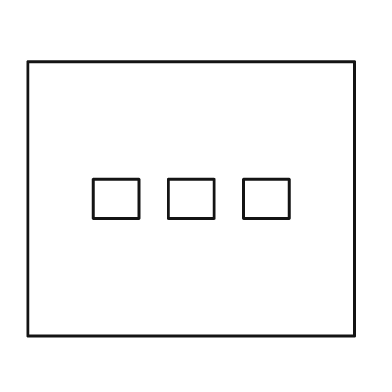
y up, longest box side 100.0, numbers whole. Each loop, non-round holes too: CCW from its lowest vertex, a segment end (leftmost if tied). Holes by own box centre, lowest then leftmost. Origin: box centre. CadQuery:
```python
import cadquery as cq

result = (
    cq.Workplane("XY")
    .moveTo(-50.0, -42.0)
    .lineTo(50.0, -42.0)
    .lineTo(50.0, 42.0)
    .lineTo(-50.0, 42.0)
    .close()
    .moveTo(-30.0, -6.0)
    .lineTo(-16.0, -6.0)
    .lineTo(-16.0, 6.0)
    .lineTo(-30.0, 6.0)
    .close()
    .moveTo(-7.0, -6.0)
    .lineTo(7.0, -6.0)
    .lineTo(7.0, 6.0)
    .lineTo(-7.0, 6.0)
    .close()
    .moveTo(16.0, -6.0)
    .lineTo(30.0, -6.0)
    .lineTo(30.0, 6.0)
    .lineTo(16.0, 6.0)
    .close()
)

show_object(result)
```